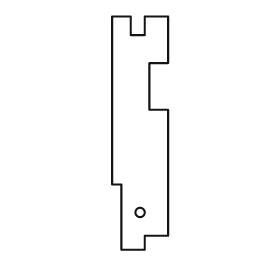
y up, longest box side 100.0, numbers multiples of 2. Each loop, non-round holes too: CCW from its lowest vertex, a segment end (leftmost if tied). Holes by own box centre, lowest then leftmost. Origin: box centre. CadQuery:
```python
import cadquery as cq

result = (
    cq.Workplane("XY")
    .moveTo(-8.0, -50.0)
    .lineTo(2.0, -50.0)
    .lineTo(2.0, -44.0)
    .lineTo(12.0, -44.0)
    .lineTo(12.0, 10.0)
    .lineTo(4.0, 10.0)
    .lineTo(4.0, 30.0)
    .lineTo(12.0, 30.0)
    .lineTo(12.0, 50.0)
    .lineTo(2.0, 50.0)
    .lineTo(2.0, 42.0)
    .lineTo(-4.0, 42.0)
    .lineTo(-4.0, 50.0)
    .lineTo(-12.0, 50.0)
    .lineTo(-12.0, -22.0)
    .lineTo(-8.0, -22.0)
    .close()
    .moveTo(0.0, -34.0)
    .circle(2.0)
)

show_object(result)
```